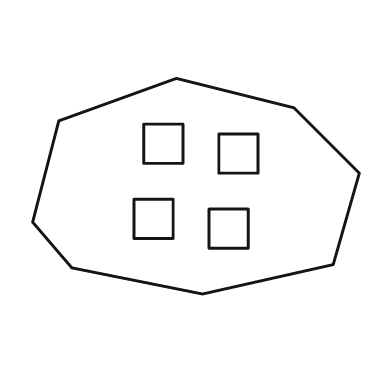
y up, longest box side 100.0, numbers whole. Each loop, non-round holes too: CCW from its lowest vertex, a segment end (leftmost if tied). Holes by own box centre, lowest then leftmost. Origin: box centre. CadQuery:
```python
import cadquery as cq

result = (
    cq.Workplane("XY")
    .moveTo(2.0, -33.0)
    .lineTo(42.0, -24.0)
    .lineTo(50.0, 4.0)
    .lineTo(30.0, 24.0)
    .lineTo(-6.0, 33.0)
    .lineTo(-42.0, 20.0)
    .lineTo(-50.0, -11.0)
    .lineTo(-38.0, -25.0)
    .close()
    .moveTo(4.0, -19.0)
    .lineTo(16.0, -19.0)
    .lineTo(16.0, -7.0)
    .lineTo(4.0, -7.0)
    .close()
    .moveTo(-19.0, -16.0)
    .lineTo(-7.0, -16.0)
    .lineTo(-7.0, -4.0)
    .lineTo(-19.0, -4.0)
    .close()
    .moveTo(7.0, 4.0)
    .lineTo(19.0, 4.0)
    .lineTo(19.0, 16.0)
    .lineTo(7.0, 16.0)
    .close()
    .moveTo(-16.0, 7.0)
    .lineTo(-4.0, 7.0)
    .lineTo(-4.0, 19.0)
    .lineTo(-16.0, 19.0)
    .close()
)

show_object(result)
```